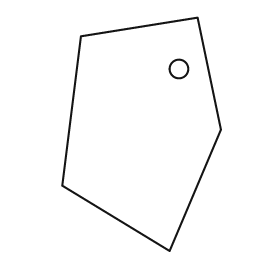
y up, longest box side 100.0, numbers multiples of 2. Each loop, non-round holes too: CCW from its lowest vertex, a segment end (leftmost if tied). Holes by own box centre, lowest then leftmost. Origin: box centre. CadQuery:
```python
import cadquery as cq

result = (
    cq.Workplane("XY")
    .moveTo(12.0, -50.0)
    .lineTo(34.0, 2.0)
    .lineTo(24.0, 50.0)
    .lineTo(-26.0, 42.0)
    .lineTo(-34.0, -22.0)
    .close()
    .moveTo(16.0, 28.0)
    .circle(4.0)
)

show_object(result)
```